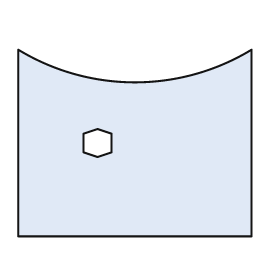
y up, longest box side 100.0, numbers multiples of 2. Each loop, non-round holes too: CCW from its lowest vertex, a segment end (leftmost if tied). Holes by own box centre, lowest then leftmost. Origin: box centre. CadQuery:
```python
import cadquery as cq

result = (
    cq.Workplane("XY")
    .moveTo(-50.0, -40.0)
    .lineTo(50.0, -40.0)
    .lineTo(50.0, 40.0)
    .threePointArc((0.0, 26.0), (-50.0, 40.0))
    .close()
    .moveTo(-16.0, -6.0)
    .lineTo(-10.0, -4.0)
    .lineTo(-10.0, 4.0)
    .lineTo(-16.0, 6.0)
    .lineTo(-22.0, 4.0)
    .lineTo(-22.0, -4.0)
    .close()
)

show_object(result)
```